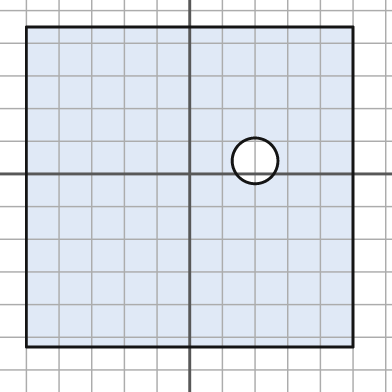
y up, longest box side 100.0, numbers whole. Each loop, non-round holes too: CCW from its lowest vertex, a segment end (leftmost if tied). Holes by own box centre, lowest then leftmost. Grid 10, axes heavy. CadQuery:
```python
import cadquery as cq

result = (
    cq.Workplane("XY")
    .moveTo(-50.0, -53.0)
    .lineTo(50.0, -53.0)
    .lineTo(50.0, 45.0)
    .lineTo(-50.0, 45.0)
    .close()
    .moveTo(20.0, 4.0)
    .circle(7.0)
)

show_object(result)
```